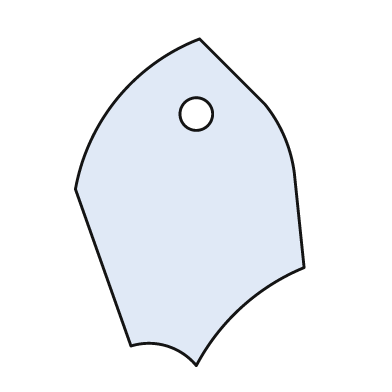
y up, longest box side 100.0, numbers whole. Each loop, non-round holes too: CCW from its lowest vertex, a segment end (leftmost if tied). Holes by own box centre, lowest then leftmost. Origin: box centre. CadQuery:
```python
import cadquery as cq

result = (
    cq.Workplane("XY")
    .moveTo(2.0, -50.0)
    .threePointArc((16.0, -32.0), (35.0, -20.0))
    .lineTo(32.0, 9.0)
    .threePointArc((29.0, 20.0), (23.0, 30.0))
    .lineTo(3.0, 50.0)
    .threePointArc((-22.0, 32.0), (-35.0, 4.0))
    .lineTo(-18.0, -44.0)
    .threePointArc((-7.0, -44.0), (2.0, -50.0))
    .close()
    .moveTo(2.0, 27.0)
    .circle(5.0)
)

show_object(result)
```